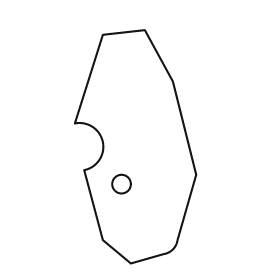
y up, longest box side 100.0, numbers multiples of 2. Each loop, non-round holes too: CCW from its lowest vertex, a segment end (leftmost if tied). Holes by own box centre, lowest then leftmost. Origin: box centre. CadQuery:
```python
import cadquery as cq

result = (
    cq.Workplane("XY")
    .moveTo(-2.0, -50.0)
    .lineTo(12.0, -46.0)
    .threePointArc((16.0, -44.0), (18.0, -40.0))
    .lineTo(26.0, -12.0)
    .lineTo(16.0, 28.0)
    .lineTo(4.0, 50.0)
    .lineTo(-14.0, 48.0)
    .lineTo(-26.0, 10.0)
    .threePointArc((-14.0, 2.0), (-22.0, -10.0))
    .lineTo(-14.0, -40.0)
    .close()
    .moveTo(-6.0, -16.0)
    .circle(4.0)
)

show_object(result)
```